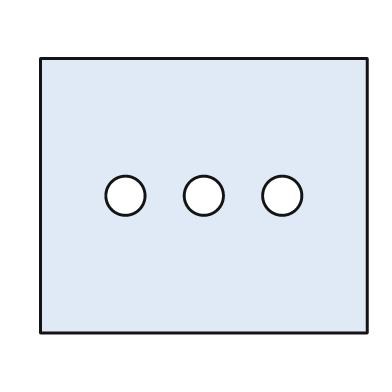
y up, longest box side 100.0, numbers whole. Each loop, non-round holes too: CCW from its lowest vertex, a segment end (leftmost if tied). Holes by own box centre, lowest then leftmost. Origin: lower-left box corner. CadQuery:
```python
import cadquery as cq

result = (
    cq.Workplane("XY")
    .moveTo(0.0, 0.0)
    .lineTo(100.0, 0.0)
    .lineTo(100.0, 84.0)
    .lineTo(0.0, 84.0)
    .close()
    .moveTo(26.0, 42.0)
    .circle(6.0)
    .moveTo(50.0, 42.0)
    .circle(6.0)
    .moveTo(74.0, 42.0)
    .circle(6.0)
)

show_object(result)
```